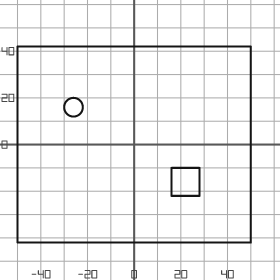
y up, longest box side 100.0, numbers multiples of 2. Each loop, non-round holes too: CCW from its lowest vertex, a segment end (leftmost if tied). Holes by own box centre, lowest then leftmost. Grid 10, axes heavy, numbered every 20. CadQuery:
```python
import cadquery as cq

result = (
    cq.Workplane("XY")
    .moveTo(-50.0, -42.0)
    .lineTo(50.0, -42.0)
    .lineTo(50.0, 42.0)
    .lineTo(-50.0, 42.0)
    .close()
    .moveTo(16.0, -22.0)
    .lineTo(28.0, -22.0)
    .lineTo(28.0, -10.0)
    .lineTo(16.0, -10.0)
    .close()
    .moveTo(-26.0, 16.0)
    .circle(4.0)
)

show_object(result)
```